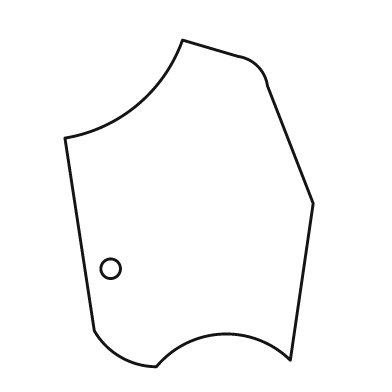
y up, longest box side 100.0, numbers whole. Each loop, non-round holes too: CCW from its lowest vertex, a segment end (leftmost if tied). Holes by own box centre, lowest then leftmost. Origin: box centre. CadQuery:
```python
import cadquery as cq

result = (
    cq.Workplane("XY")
    .moveTo(-10.0, -50.0)
    .threePointArc((10.0, -40.0), (31.0, -48.0))
    .lineTo(38.0, 0.0)
    .lineTo(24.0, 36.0)
    .threePointArc((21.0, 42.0), (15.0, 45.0))
    .lineTo(-2.0, 50.0)
    .threePointArc((-16.0, 30.0), (-38.0, 20.0))
    .lineTo(-29.0, -39.0)
    .threePointArc((-21.0, -47.0), (-10.0, -50.0))
    .close()
    .moveTo(-24.0, -20.0)
    .circle(3.0)
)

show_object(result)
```